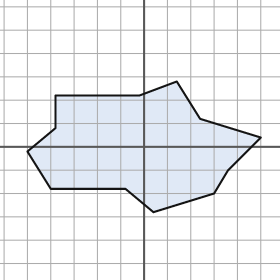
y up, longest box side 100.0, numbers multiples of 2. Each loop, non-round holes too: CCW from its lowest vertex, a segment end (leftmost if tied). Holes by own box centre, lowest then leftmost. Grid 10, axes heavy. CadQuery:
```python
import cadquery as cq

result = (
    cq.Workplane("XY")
    .moveTo(4.0, -28.0)
    .lineTo(30.0, -20.0)
    .lineTo(36.0, -10.0)
    .lineTo(50.0, 4.0)
    .lineTo(24.0, 12.0)
    .lineTo(14.0, 28.0)
    .lineTo(-2.0, 22.0)
    .lineTo(-38.0, 22.0)
    .lineTo(-38.0, 8.0)
    .lineTo(-50.0, -2.0)
    .lineTo(-40.0, -18.0)
    .lineTo(-8.0, -18.0)
    .close()
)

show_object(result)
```